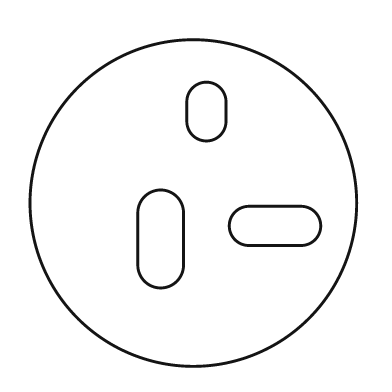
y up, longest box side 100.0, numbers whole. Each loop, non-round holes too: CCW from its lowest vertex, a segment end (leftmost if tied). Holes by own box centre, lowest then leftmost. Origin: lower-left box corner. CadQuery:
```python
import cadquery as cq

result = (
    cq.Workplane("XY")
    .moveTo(50.0, 50.0)
    .circle(50.0)
    .moveTo(33.0, 31.0)
    .threePointArc((40.0, 24.0), (47.0, 31.0))
    .lineTo(47.0, 47.0)
    .threePointArc((40.0, 54.0), (33.0, 47.0))
    .close()
    .moveTo(67.0, 37.0)
    .lineTo(83.0, 37.0)
    .threePointArc((89.0, 43.0), (83.0, 49.0))
    .lineTo(67.0, 49.0)
    .threePointArc((61.0, 43.0), (67.0, 37.0))
    .close()
    .moveTo(48.0, 75.0)
    .threePointArc((54.0, 69.0), (60.0, 75.0))
    .lineTo(60.0, 81.0)
    .threePointArc((54.0, 87.0), (48.0, 81.0))
    .close()
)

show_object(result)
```